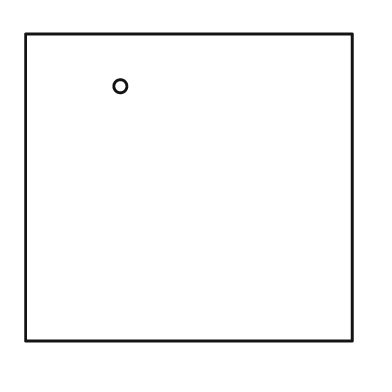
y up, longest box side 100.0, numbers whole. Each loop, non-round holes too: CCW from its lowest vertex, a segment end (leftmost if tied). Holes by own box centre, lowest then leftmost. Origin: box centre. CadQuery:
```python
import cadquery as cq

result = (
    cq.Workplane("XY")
    .moveTo(-50.0, -47.0)
    .lineTo(50.0, -47.0)
    .lineTo(50.0, 47.0)
    .lineTo(-50.0, 47.0)
    .close()
    .moveTo(-21.0, 31.0)
    .circle(2.0)
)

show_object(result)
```